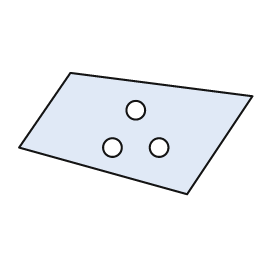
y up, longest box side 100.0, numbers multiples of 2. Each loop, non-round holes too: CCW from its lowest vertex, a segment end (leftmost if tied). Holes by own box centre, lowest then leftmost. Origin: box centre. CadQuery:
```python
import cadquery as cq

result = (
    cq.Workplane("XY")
    .moveTo(22.0, -26.0)
    .lineTo(50.0, 16.0)
    .lineTo(-28.0, 26.0)
    .lineTo(-50.0, -6.0)
    .close()
    .moveTo(-10.0, -6.0)
    .circle(4.0)
    .moveTo(10.0, -6.0)
    .circle(4.0)
    .moveTo(0.0, 10.0)
    .circle(4.0)
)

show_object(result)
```